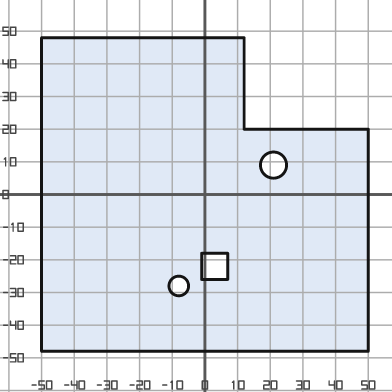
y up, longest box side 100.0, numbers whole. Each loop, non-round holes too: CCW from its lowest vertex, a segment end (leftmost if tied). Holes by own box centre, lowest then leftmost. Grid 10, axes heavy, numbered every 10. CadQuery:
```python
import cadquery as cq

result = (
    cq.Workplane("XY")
    .moveTo(-50.0, -48.0)
    .lineTo(50.0, -48.0)
    .lineTo(50.0, 20.0)
    .lineTo(12.0, 20.0)
    .lineTo(12.0, 48.0)
    .lineTo(-50.0, 48.0)
    .close()
    .moveTo(-8.0, -28.0)
    .circle(3.0)
    .moveTo(-1.0, -26.0)
    .lineTo(7.0, -26.0)
    .lineTo(7.0, -18.0)
    .lineTo(-1.0, -18.0)
    .close()
    .moveTo(21.0, 9.0)
    .circle(4.0)
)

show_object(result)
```